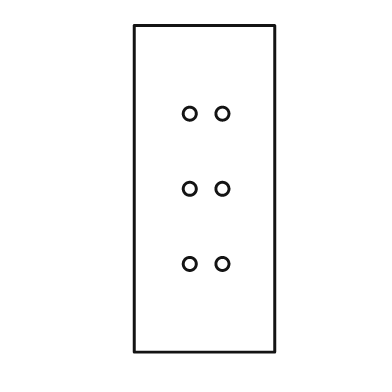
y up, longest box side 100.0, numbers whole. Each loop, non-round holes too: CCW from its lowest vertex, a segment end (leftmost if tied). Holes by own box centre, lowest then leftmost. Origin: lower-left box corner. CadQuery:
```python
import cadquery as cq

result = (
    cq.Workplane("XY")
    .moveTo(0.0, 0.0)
    .lineTo(43.0, 0.0)
    .lineTo(43.0, 100.0)
    .lineTo(0.0, 100.0)
    .close()
    .moveTo(17.0, 27.0)
    .circle(2.0)
    .moveTo(27.0, 27.0)
    .circle(2.0)
    .moveTo(17.0, 50.0)
    .circle(2.0)
    .moveTo(27.0, 50.0)
    .circle(2.0)
    .moveTo(17.0, 73.0)
    .circle(2.0)
    .moveTo(27.0, 73.0)
    .circle(2.0)
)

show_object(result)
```